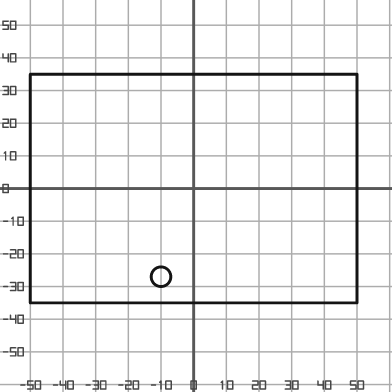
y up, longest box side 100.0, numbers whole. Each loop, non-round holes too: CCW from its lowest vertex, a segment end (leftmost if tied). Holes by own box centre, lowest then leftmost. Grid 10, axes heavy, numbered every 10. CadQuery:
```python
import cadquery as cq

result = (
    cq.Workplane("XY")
    .moveTo(-50.0, -35.0)
    .lineTo(50.0, -35.0)
    .lineTo(50.0, 35.0)
    .lineTo(-50.0, 35.0)
    .close()
    .moveTo(-10.0, -27.0)
    .circle(3.0)
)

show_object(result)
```